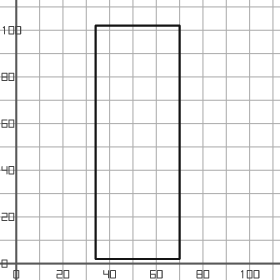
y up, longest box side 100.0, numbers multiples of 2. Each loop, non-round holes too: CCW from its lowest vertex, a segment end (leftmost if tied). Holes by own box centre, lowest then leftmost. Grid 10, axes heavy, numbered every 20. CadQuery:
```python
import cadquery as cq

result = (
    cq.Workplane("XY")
    .moveTo(34.0, 2.0)
    .lineTo(70.0, 2.0)
    .lineTo(70.0, 102.0)
    .lineTo(34.0, 102.0)
    .close()
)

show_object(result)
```